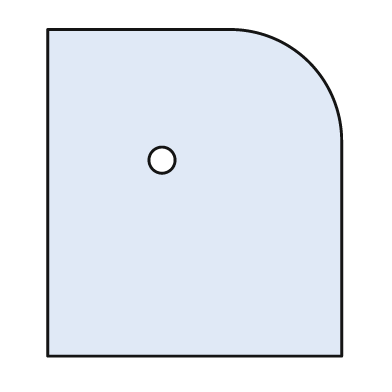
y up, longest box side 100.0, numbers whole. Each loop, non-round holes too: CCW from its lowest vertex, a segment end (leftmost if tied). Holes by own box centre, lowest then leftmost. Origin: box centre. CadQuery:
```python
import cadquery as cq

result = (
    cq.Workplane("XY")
    .moveTo(-45.0, -50.0)
    .lineTo(45.0, -50.0)
    .lineTo(45.0, 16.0)
    .threePointArc((35.0, 40.0), (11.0, 50.0))
    .lineTo(-45.0, 50.0)
    .close()
    .moveTo(-10.0, 10.0)
    .circle(4.0)
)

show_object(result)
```